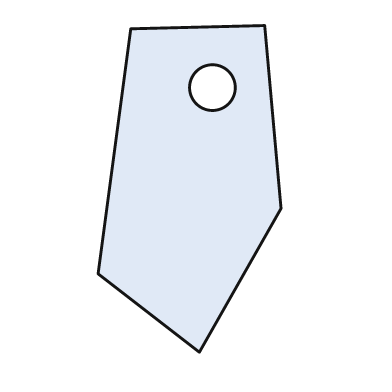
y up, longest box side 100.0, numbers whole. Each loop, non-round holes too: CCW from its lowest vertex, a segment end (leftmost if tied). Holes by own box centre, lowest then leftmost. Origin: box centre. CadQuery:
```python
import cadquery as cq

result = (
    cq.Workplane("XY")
    .moveTo(3.0, -50.0)
    .lineTo(28.0, -6.0)
    .lineTo(23.0, 50.0)
    .lineTo(-18.0, 49.0)
    .lineTo(-28.0, -26.0)
    .close()
    .moveTo(7.0, 31.0)
    .circle(7.0)
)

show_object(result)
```